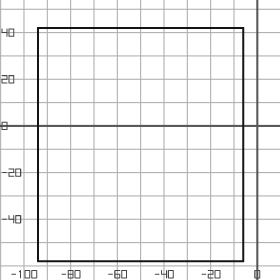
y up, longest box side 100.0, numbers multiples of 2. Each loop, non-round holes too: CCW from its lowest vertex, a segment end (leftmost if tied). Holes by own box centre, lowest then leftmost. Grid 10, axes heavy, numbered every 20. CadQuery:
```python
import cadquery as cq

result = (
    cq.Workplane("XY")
    .moveTo(-94.0, -58.0)
    .lineTo(-6.0, -58.0)
    .lineTo(-6.0, 42.0)
    .lineTo(-94.0, 42.0)
    .close()
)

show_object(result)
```